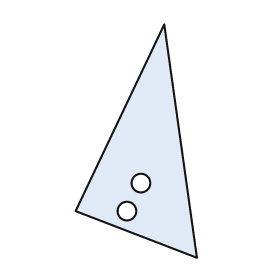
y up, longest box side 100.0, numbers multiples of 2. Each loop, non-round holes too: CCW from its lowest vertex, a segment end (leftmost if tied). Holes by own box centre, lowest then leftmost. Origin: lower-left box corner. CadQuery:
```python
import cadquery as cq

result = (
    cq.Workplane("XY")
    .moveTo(52.0, 0.0)
    .lineTo(38.0, 100.0)
    .lineTo(0.0, 20.0)
    .close()
    .moveTo(22.0, 20.0)
    .circle(4.0)
    .moveTo(28.0, 32.0)
    .circle(4.0)
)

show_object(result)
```